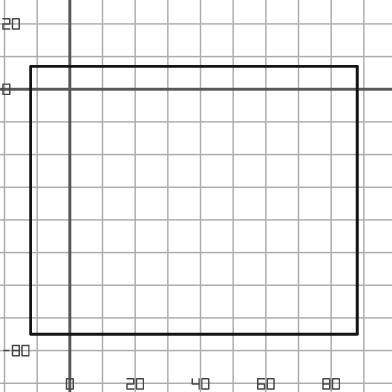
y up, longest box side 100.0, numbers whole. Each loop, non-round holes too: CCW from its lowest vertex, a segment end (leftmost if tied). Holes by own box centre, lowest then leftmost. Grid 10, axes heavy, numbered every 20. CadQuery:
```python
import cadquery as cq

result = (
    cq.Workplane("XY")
    .moveTo(-12.0, -75.0)
    .lineTo(88.0, -75.0)
    .lineTo(88.0, 7.0)
    .lineTo(-12.0, 7.0)
    .close()
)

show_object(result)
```